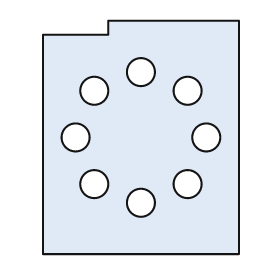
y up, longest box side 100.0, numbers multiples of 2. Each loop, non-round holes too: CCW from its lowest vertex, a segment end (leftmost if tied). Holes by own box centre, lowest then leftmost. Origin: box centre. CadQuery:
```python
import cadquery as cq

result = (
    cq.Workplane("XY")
    .moveTo(-42.0, -50.0)
    .lineTo(42.0, -50.0)
    .lineTo(42.0, 50.0)
    .lineTo(-14.0, 50.0)
    .lineTo(-14.0, 44.0)
    .lineTo(-42.0, 44.0)
    .close()
    .moveTo(0.0, -28.0)
    .circle(6.0)
    .moveTo(-20.0, -20.0)
    .circle(6.0)
    .moveTo(20.0, -20.0)
    .circle(6.0)
    .moveTo(-28.0, 0.0)
    .circle(6.0)
    .moveTo(28.0, 0.0)
    .circle(6.0)
    .moveTo(-20.0, 20.0)
    .circle(6.0)
    .moveTo(20.0, 20.0)
    .circle(6.0)
    .moveTo(0.0, 28.0)
    .circle(6.0)
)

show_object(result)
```